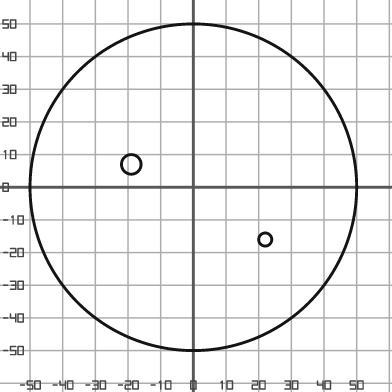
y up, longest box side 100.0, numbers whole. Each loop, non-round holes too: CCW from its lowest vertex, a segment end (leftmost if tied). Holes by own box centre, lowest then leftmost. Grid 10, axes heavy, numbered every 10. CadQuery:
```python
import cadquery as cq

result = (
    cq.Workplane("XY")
    .moveTo(0.0, 0.0)
    .circle(50.0)
    .moveTo(22.0, -16.0)
    .circle(2.0)
    .moveTo(-19.0, 7.0)
    .circle(3.0)
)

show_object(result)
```